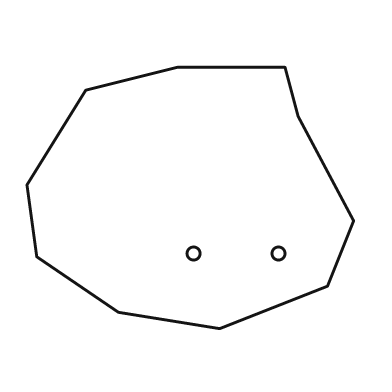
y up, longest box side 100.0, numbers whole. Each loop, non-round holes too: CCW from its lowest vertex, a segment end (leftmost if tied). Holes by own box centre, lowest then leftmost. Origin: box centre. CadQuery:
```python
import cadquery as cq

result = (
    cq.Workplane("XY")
    .moveTo(9.0, -40.0)
    .lineTo(42.0, -27.0)
    .lineTo(50.0, -7.0)
    .lineTo(33.0, 25.0)
    .lineTo(29.0, 40.0)
    .lineTo(-4.0, 40.0)
    .lineTo(-32.0, 33.0)
    .lineTo(-50.0, 4.0)
    .lineTo(-47.0, -18.0)
    .lineTo(-22.0, -35.0)
    .close()
    .moveTo(1.0, -17.0)
    .circle(2.0)
    .moveTo(27.0, -17.0)
    .circle(2.0)
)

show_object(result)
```